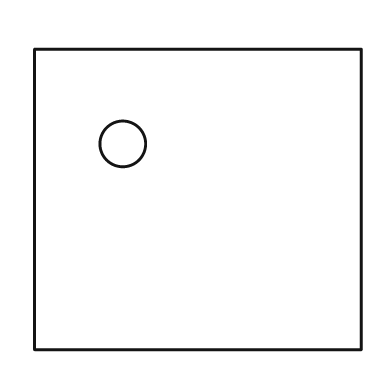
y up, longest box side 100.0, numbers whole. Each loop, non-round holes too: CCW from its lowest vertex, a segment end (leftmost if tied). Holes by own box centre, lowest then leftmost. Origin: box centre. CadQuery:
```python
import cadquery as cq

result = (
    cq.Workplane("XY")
    .moveTo(-50.0, -46.0)
    .lineTo(50.0, -46.0)
    .lineTo(50.0, 46.0)
    .lineTo(-50.0, 46.0)
    .close()
    .moveTo(-23.0, 17.0)
    .circle(7.0)
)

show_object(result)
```